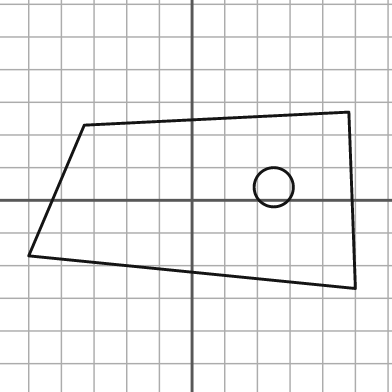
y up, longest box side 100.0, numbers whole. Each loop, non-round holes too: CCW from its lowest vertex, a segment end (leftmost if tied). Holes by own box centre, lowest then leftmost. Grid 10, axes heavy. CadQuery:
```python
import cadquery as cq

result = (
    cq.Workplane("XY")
    .moveTo(50.0, -27.0)
    .lineTo(48.0, 27.0)
    .lineTo(-33.0, 23.0)
    .lineTo(-50.0, -17.0)
    .close()
    .moveTo(25.0, 4.0)
    .circle(6.0)
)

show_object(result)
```